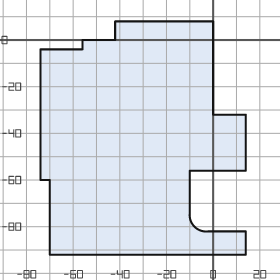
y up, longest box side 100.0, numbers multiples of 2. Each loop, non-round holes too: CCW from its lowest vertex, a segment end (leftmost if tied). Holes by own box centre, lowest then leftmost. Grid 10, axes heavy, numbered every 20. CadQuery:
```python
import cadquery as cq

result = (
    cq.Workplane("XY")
    .moveTo(-70.0, -92.0)
    .lineTo(14.0, -92.0)
    .lineTo(14.0, -82.0)
    .lineTo(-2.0, -82.0)
    .threePointArc((-8.0, -80.0), (-10.0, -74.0))
    .lineTo(-10.0, -56.0)
    .lineTo(14.0, -56.0)
    .lineTo(14.0, -32.0)
    .lineTo(0.0, -32.0)
    .lineTo(0.0, 8.0)
    .lineTo(-42.0, 8.0)
    .lineTo(-42.0, 0.0)
    .lineTo(-56.0, 0.0)
    .lineTo(-56.0, -4.0)
    .lineTo(-74.0, -4.0)
    .lineTo(-74.0, -60.0)
    .lineTo(-70.0, -60.0)
    .close()
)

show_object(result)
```